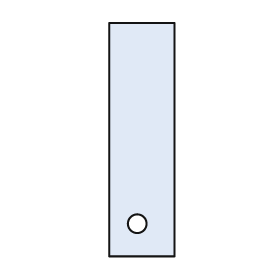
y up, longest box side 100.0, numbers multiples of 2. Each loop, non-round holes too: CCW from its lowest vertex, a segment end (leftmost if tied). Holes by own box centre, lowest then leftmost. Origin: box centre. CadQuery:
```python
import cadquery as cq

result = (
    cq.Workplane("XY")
    .moveTo(-14.0, -50.0)
    .lineTo(14.0, -50.0)
    .lineTo(14.0, 50.0)
    .lineTo(-14.0, 50.0)
    .close()
    .moveTo(-2.0, -36.0)
    .circle(4.0)
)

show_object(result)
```